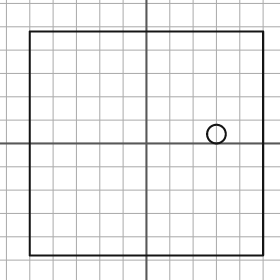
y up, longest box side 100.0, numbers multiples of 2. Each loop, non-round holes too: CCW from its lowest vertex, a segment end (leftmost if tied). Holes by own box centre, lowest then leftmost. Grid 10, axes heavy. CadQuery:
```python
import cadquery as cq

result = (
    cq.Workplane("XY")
    .moveTo(-50.0, -48.0)
    .lineTo(50.0, -48.0)
    .lineTo(50.0, 48.0)
    .lineTo(-50.0, 48.0)
    .close()
    .moveTo(30.0, 4.0)
    .circle(4.0)
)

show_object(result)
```